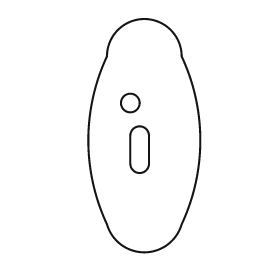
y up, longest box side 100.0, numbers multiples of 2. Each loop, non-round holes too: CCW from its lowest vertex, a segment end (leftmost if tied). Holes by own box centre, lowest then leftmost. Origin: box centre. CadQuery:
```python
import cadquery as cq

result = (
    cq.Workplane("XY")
    .moveTo(-16.0, -38.0)
    .threePointArc((0.0, -50.0), (16.0, -38.0))
    .threePointArc((24.0, -2.0), (16.0, 34.0))
    .threePointArc((0.0, 50.0), (-16.0, 34.0))
    .threePointArc((-24.0, -2.0), (-16.0, -38.0))
    .close()
    .moveTo(-6.0, -12.0)
    .threePointArc((-2.0, -16.0), (2.0, -12.0))
    .lineTo(2.0, 0.0)
    .threePointArc((-2.0, 4.0), (-6.0, 0.0))
    .close()
    .moveTo(-6.0, 14.0)
    .circle(4.0)
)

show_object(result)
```